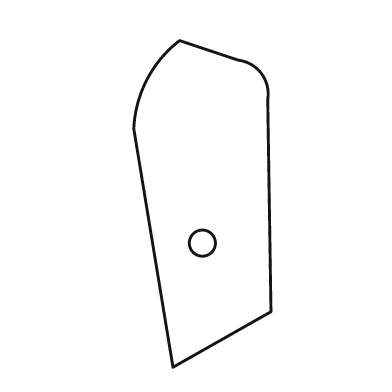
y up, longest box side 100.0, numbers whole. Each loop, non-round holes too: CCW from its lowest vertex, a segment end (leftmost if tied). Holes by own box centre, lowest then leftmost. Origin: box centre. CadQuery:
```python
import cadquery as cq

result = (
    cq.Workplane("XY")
    .moveTo(-9.0, -50.0)
    .lineTo(21.0, -33.0)
    .lineTo(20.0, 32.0)
    .threePointArc((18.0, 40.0), (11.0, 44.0))
    .lineTo(-7.0, 50.0)
    .threePointArc((-17.0, 38.0), (-21.0, 23.0))
    .close()
    .moveTo(0.0, -12.0)
    .circle(4.0)
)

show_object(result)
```